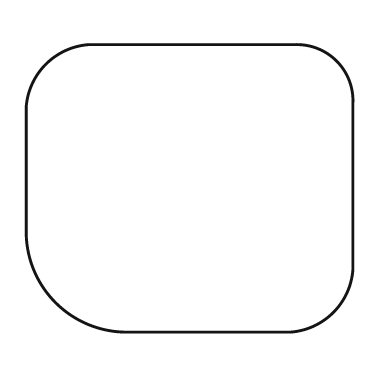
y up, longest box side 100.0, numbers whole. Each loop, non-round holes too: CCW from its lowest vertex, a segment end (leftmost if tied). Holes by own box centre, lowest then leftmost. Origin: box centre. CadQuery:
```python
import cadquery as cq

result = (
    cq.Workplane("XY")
    .moveTo(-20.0, -44.0)
    .lineTo(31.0, -44.0)
    .threePointArc((44.0, -38.0), (50.0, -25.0))
    .lineTo(50.0, 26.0)
    .threePointArc((45.0, 39.0), (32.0, 44.0))
    .lineTo(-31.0, 44.0)
    .threePointArc((-44.0, 38.0), (-50.0, 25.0))
    .lineTo(-50.0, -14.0)
    .threePointArc((-41.0, -35.0), (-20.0, -44.0))
    .close()
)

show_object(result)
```